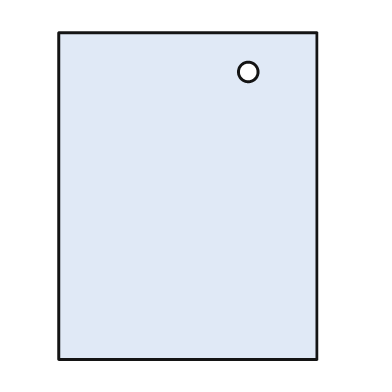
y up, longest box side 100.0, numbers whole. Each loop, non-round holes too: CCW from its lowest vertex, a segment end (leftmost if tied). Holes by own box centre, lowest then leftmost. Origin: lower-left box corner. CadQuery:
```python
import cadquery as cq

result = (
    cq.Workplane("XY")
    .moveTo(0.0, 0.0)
    .lineTo(79.0, 0.0)
    .lineTo(79.0, 100.0)
    .lineTo(0.0, 100.0)
    .close()
    .moveTo(58.0, 88.0)
    .circle(3.0)
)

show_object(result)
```